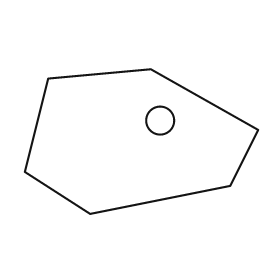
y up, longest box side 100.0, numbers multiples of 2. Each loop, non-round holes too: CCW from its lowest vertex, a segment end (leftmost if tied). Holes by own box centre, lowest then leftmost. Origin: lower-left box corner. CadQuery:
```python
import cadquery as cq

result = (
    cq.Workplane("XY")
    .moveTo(28.0, 0.0)
    .lineTo(88.0, 12.0)
    .lineTo(100.0, 36.0)
    .lineTo(54.0, 62.0)
    .lineTo(10.0, 58.0)
    .lineTo(0.0, 18.0)
    .close()
    .moveTo(58.0, 40.0)
    .circle(6.0)
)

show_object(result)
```